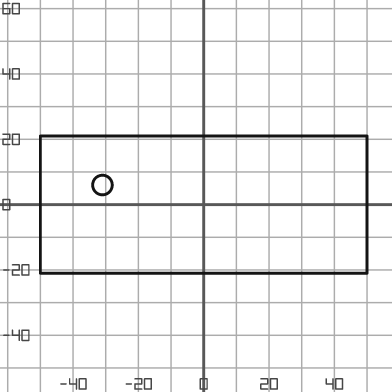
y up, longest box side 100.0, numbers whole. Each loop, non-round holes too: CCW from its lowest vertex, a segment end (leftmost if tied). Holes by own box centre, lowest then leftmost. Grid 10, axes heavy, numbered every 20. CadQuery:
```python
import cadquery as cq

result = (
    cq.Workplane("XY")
    .moveTo(-50.0, -21.0)
    .lineTo(50.0, -21.0)
    .lineTo(50.0, 21.0)
    .lineTo(-50.0, 21.0)
    .close()
    .moveTo(-31.0, 6.0)
    .circle(3.0)
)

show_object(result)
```